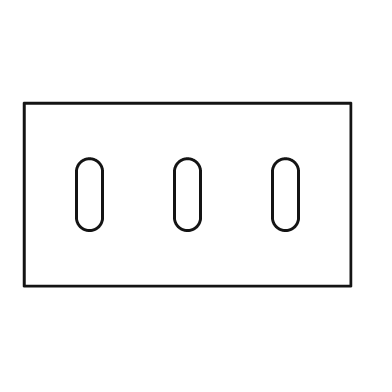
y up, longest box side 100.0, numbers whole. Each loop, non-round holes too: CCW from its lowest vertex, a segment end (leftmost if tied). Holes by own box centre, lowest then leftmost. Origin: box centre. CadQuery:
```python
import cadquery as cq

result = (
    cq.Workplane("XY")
    .moveTo(-50.0, -28.0)
    .lineTo(50.0, -28.0)
    .lineTo(50.0, 28.0)
    .lineTo(-50.0, 28.0)
    .close()
    .moveTo(-34.0, -7.0)
    .threePointArc((-30.0, -11.0), (-26.0, -7.0))
    .lineTo(-26.0, 7.0)
    .threePointArc((-30.0, 11.0), (-34.0, 7.0))
    .close()
    .moveTo(-4.0, -7.0)
    .threePointArc((0.0, -11.0), (4.0, -7.0))
    .lineTo(4.0, 7.0)
    .threePointArc((0.0, 11.0), (-4.0, 7.0))
    .close()
    .moveTo(26.0, -7.0)
    .threePointArc((30.0, -11.0), (34.0, -7.0))
    .lineTo(34.0, 7.0)
    .threePointArc((30.0, 11.0), (26.0, 7.0))
    .close()
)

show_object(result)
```